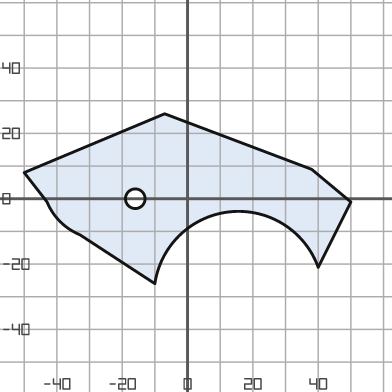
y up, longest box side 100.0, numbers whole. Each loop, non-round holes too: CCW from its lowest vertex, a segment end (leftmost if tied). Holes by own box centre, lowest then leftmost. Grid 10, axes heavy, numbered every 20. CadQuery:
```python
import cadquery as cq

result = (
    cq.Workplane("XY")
    .moveTo(-10.0, -26.0)
    .threePointArc((13.0, -4.0), (40.0, -21.0))
    .lineTo(50.0, -1.0)
    .lineTo(38.0, 9.0)
    .lineTo(-7.0, 26.0)
    .lineTo(-50.0, 8.0)
    .lineTo(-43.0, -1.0)
    .threePointArc((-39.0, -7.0), (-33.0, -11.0))
    .close()
    .moveTo(-16.0, 0.0)
    .circle(3.0)
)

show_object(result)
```